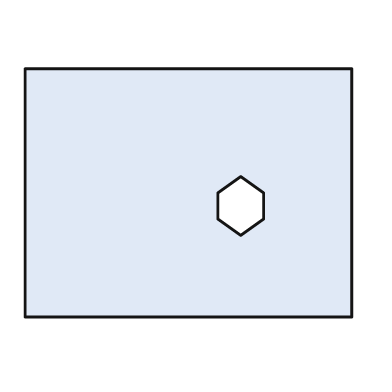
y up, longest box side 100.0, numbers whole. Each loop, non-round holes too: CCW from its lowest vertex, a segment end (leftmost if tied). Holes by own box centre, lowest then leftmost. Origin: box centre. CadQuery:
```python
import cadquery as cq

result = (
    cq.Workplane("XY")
    .moveTo(-50.0, -38.0)
    .lineTo(50.0, -38.0)
    .lineTo(50.0, 38.0)
    .lineTo(-50.0, 38.0)
    .close()
    .moveTo(16.0, -13.0)
    .lineTo(23.0, -8.0)
    .lineTo(23.0, 0.0)
    .lineTo(16.0, 5.0)
    .lineTo(9.0, 0.0)
    .lineTo(9.0, -8.0)
    .close()
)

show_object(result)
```